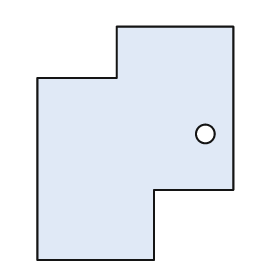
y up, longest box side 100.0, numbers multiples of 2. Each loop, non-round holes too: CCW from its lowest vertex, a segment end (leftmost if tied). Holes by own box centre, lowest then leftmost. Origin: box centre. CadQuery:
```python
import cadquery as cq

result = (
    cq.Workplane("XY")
    .moveTo(-42.0, -50.0)
    .lineTo(8.0, -50.0)
    .lineTo(8.0, -20.0)
    .lineTo(42.0, -20.0)
    .lineTo(42.0, 50.0)
    .lineTo(-8.0, 50.0)
    .lineTo(-8.0, 28.0)
    .lineTo(-42.0, 28.0)
    .close()
    .moveTo(30.0, 4.0)
    .circle(4.0)
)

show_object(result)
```